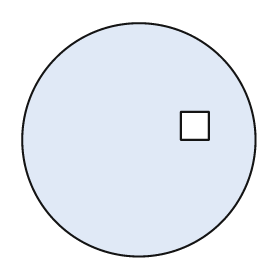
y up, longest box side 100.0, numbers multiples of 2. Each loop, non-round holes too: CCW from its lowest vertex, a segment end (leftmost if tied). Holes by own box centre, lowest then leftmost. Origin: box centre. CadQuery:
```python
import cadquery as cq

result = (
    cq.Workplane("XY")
    .moveTo(0.0, 0.0)
    .circle(50.0)
    .moveTo(18.0, 0.0)
    .lineTo(30.0, 0.0)
    .lineTo(30.0, 12.0)
    .lineTo(18.0, 12.0)
    .close()
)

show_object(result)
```